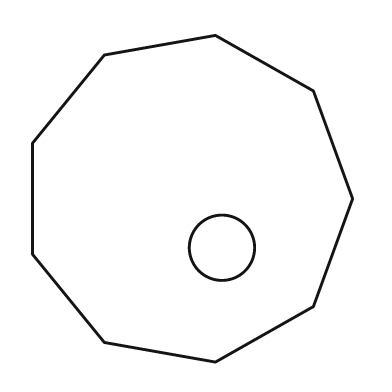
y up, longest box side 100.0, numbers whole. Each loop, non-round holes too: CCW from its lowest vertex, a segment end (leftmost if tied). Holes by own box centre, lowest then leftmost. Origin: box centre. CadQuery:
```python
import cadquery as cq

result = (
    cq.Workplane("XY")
    .moveTo(7.0, -50.0)
    .lineTo(37.0, -33.0)
    .lineTo(49.0, 0.0)
    .lineTo(37.0, 33.0)
    .lineTo(7.0, 50.0)
    .lineTo(-27.0, 44.0)
    .lineTo(-49.0, 17.0)
    .lineTo(-49.0, -17.0)
    .lineTo(-27.0, -44.0)
    .close()
    .moveTo(9.0, -15.0)
    .circle(10.0)
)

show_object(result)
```